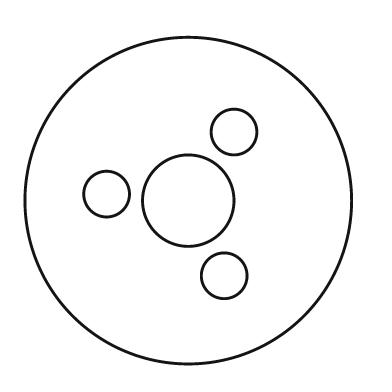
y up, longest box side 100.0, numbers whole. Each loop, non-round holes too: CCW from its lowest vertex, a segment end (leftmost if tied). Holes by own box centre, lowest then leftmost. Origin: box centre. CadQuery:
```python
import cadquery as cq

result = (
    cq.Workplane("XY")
    .moveTo(0.0, 0.0)
    .circle(50.0)
    .moveTo(11.0, -23.0)
    .circle(7.0)
    .moveTo(0.0, 0.0)
    .circle(14.0)
    .moveTo(-25.0, 2.0)
    .circle(7.0)
    .moveTo(14.0, 21.0)
    .circle(7.0)
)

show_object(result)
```